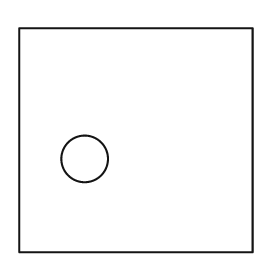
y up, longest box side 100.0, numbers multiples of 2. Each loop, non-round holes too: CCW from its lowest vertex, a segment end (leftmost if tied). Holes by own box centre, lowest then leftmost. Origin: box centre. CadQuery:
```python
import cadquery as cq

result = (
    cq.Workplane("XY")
    .moveTo(-50.0, -48.0)
    .lineTo(50.0, -48.0)
    .lineTo(50.0, 48.0)
    .lineTo(-50.0, 48.0)
    .close()
    .moveTo(-22.0, -8.0)
    .circle(10.0)
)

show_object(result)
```